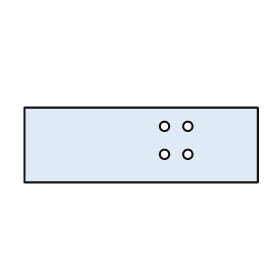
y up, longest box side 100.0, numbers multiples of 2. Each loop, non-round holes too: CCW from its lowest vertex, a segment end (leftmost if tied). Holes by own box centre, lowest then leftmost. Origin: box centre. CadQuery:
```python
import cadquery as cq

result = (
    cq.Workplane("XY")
    .moveTo(-50.0, -16.0)
    .lineTo(50.0, -16.0)
    .lineTo(50.0, 16.0)
    .lineTo(-50.0, 16.0)
    .close()
    .moveTo(10.0, -4.0)
    .circle(2.0)
    .moveTo(20.0, -4.0)
    .circle(2.0)
    .moveTo(10.0, 8.0)
    .circle(2.0)
    .moveTo(20.0, 8.0)
    .circle(2.0)
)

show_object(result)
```